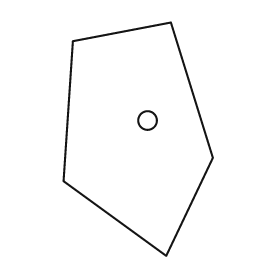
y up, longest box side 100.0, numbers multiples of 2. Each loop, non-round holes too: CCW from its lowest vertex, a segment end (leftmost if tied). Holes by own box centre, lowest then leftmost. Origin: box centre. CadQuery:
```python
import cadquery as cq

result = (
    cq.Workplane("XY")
    .moveTo(12.0, -50.0)
    .lineTo(32.0, -8.0)
    .lineTo(14.0, 50.0)
    .lineTo(-28.0, 42.0)
    .lineTo(-32.0, -18.0)
    .close()
    .moveTo(4.0, 8.0)
    .circle(4.0)
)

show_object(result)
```